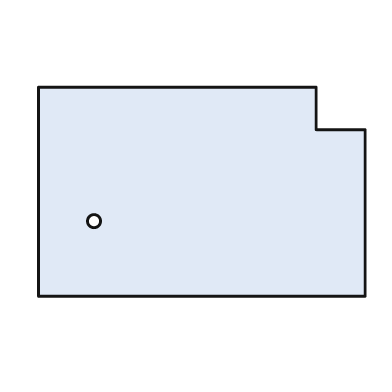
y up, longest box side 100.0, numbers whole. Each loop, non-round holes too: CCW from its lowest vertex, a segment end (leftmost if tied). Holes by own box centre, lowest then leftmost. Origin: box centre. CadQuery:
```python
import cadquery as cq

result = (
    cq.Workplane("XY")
    .moveTo(-50.0, -32.0)
    .lineTo(50.0, -32.0)
    .lineTo(50.0, 19.0)
    .lineTo(35.0, 19.0)
    .lineTo(35.0, 32.0)
    .lineTo(-50.0, 32.0)
    .close()
    .moveTo(-33.0, -9.0)
    .circle(2.0)
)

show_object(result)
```